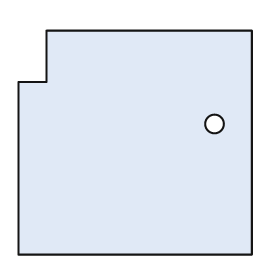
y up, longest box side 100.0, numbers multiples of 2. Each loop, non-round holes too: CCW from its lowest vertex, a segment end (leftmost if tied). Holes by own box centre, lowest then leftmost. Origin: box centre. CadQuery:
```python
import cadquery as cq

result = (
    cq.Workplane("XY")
    .moveTo(-50.0, -48.0)
    .lineTo(50.0, -48.0)
    .lineTo(50.0, 48.0)
    .lineTo(-38.0, 48.0)
    .lineTo(-38.0, 26.0)
    .lineTo(-50.0, 26.0)
    .close()
    .moveTo(34.0, 8.0)
    .circle(4.0)
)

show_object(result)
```